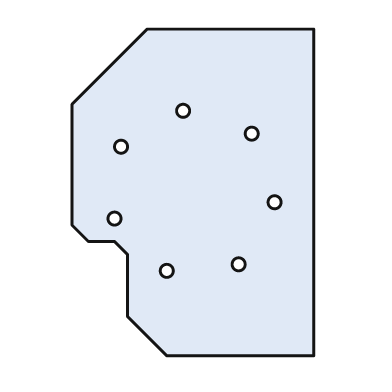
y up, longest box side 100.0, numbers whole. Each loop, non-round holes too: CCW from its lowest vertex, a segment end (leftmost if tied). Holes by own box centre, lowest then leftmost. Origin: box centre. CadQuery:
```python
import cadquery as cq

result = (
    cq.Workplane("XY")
    .moveTo(-8.0, -50.0)
    .lineTo(37.0, -50.0)
    .lineTo(37.0, 50.0)
    .lineTo(-14.0, 50.0)
    .lineTo(-37.0, 27.0)
    .lineTo(-37.0, -10.0)
    .lineTo(-32.0, -15.0)
    .lineTo(-24.0, -15.0)
    .lineTo(-20.0, -19.0)
    .lineTo(-20.0, -38.0)
    .close()
    .moveTo(-8.0, -24.0)
    .circle(2.0)
    .moveTo(14.0, -22.0)
    .circle(2.0)
    .moveTo(-24.0, -8.0)
    .circle(2.0)
    .moveTo(25.0, -3.0)
    .circle(2.0)
    .moveTo(-22.0, 14.0)
    .circle(2.0)
    .moveTo(18.0, 18.0)
    .circle(2.0)
    .moveTo(-3.0, 25.0)
    .circle(2.0)
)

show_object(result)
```